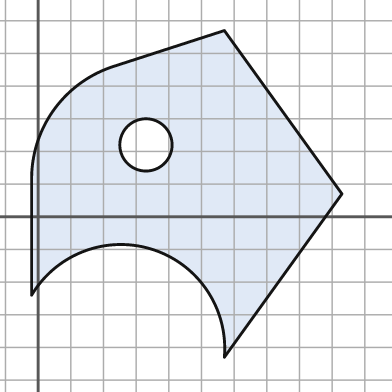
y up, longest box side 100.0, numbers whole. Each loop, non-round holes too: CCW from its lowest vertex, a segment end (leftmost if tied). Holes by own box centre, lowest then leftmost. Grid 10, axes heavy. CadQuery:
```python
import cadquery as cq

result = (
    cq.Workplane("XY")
    .moveTo(57.0, -43.0)
    .lineTo(93.0, 7.0)
    .lineTo(57.0, 57.0)
    .lineTo(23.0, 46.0)
    .threePointArc((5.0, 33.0), (-2.0, 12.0))
    .lineTo(-2.0, -24.0)
    .threePointArc((35.0, -10.0), (57.0, -43.0))
    .close()
    .moveTo(33.0, 22.0)
    .circle(8.0)
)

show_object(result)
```